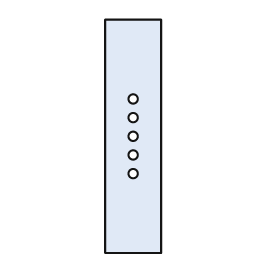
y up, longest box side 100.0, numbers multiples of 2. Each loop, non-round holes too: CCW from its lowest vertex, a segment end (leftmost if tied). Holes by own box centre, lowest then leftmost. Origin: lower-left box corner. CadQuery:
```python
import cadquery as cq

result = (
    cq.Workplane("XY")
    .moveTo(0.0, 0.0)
    .lineTo(24.0, 0.0)
    .lineTo(24.0, 100.0)
    .lineTo(0.0, 100.0)
    .close()
    .moveTo(12.0, 34.0)
    .circle(2.0)
    .moveTo(12.0, 42.0)
    .circle(2.0)
    .moveTo(12.0, 50.0)
    .circle(2.0)
    .moveTo(12.0, 58.0)
    .circle(2.0)
    .moveTo(12.0, 66.0)
    .circle(2.0)
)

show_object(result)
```